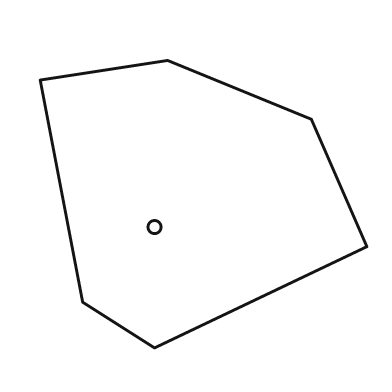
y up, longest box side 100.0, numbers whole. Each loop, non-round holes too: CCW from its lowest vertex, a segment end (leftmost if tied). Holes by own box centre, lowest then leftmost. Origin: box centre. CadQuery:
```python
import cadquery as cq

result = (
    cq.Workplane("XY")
    .moveTo(-15.0, -44.0)
    .lineTo(50.0, -13.0)
    .lineTo(33.0, 26.0)
    .lineTo(-11.0, 44.0)
    .lineTo(-50.0, 38.0)
    .lineTo(-37.0, -30.0)
    .close()
    .moveTo(-15.0, -7.0)
    .circle(2.0)
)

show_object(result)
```